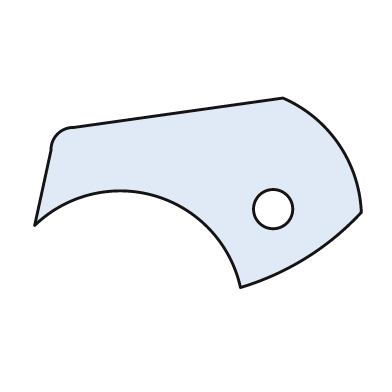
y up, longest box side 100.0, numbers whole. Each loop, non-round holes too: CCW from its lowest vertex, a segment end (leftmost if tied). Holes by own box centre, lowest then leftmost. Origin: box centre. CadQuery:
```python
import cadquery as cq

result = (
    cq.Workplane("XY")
    .moveTo(13.0, -29.0)
    .threePointArc((33.0, -20.0), (50.0, -6.0))
    .threePointArc((43.0, 15.0), (26.0, 29.0))
    .lineTo(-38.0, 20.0)
    .threePointArc((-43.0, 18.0), (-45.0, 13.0))
    .lineTo(-50.0, -10.0)
    .threePointArc((-13.0, -1.0), (13.0, -29.0))
    .close()
    .moveTo(23.0, -5.0)
    .circle(6.0)
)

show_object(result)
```